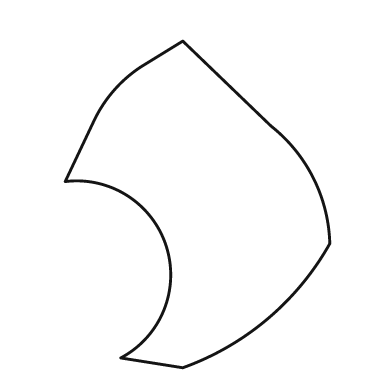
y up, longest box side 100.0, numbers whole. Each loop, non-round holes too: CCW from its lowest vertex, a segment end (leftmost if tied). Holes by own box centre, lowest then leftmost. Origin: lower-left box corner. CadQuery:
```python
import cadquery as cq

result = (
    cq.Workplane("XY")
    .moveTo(36.0, 0.0)
    .threePointArc((62.0, 15.0), (81.0, 38.0))
    .threePointArc((76.0, 58.0), (63.0, 74.0))
    .lineTo(36.0, 100.0)
    .lineTo(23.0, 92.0)
    .threePointArc((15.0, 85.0), (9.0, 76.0))
    .lineTo(0.0, 57.0)
    .threePointArc((31.0, 37.0), (17.0, 3.0))
    .close()
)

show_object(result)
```